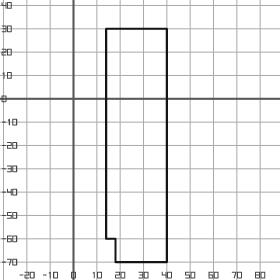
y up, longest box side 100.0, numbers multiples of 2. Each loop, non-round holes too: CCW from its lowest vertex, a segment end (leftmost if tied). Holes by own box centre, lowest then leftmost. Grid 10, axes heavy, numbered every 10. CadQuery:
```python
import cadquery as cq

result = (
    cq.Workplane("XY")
    .moveTo(18.0, -70.0)
    .lineTo(40.0, -70.0)
    .lineTo(40.0, 30.0)
    .lineTo(14.0, 30.0)
    .lineTo(14.0, -60.0)
    .lineTo(18.0, -60.0)
    .close()
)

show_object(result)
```